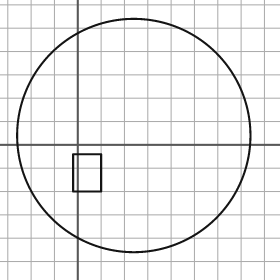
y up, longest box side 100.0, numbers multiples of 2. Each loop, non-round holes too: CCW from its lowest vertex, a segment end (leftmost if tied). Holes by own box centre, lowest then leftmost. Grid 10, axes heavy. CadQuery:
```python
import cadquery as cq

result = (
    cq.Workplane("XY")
    .moveTo(24.0, 4.0)
    .circle(50.0)
    .moveTo(-2.0, -20.0)
    .lineTo(10.0, -20.0)
    .lineTo(10.0, -4.0)
    .lineTo(-2.0, -4.0)
    .close()
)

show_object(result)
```